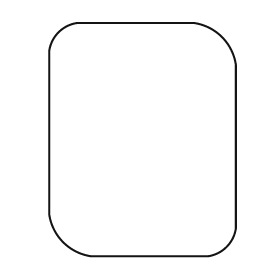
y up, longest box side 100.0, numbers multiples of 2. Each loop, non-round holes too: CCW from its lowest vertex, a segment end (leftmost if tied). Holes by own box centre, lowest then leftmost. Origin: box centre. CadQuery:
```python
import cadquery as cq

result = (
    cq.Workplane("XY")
    .moveTo(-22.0, -50.0)
    .lineTo(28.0, -50.0)
    .threePointArc((36.0, -46.0), (40.0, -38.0))
    .lineTo(40.0, 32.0)
    .threePointArc((34.0, 44.0), (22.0, 50.0))
    .lineTo(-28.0, 50.0)
    .threePointArc((-36.0, 46.0), (-40.0, 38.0))
    .lineTo(-40.0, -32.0)
    .threePointArc((-34.0, -44.0), (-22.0, -50.0))
    .close()
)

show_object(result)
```